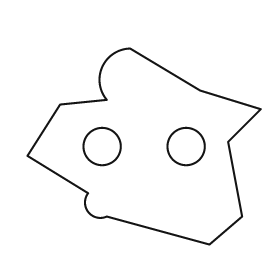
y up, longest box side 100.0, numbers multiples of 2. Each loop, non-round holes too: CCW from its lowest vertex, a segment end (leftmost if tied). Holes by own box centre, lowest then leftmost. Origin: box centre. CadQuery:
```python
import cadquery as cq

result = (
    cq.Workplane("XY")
    .moveTo(28.0, -42.0)
    .lineTo(42.0, -30.0)
    .lineTo(36.0, 2.0)
    .lineTo(50.0, 16.0)
    .lineTo(24.0, 24.0)
    .lineTo(-6.0, 42.0)
    .threePointArc((-18.0, 34.0), (-16.0, 20.0))
    .lineTo(-36.0, 18.0)
    .lineTo(-50.0, -4.0)
    .lineTo(-24.0, -20.0)
    .threePointArc((-24.0, -28.0), (-16.0, -30.0))
    .close()
    .moveTo(-18.0, 0.0)
    .circle(8.0)
    .moveTo(18.0, 0.0)
    .circle(8.0)
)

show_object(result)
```